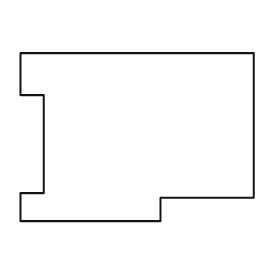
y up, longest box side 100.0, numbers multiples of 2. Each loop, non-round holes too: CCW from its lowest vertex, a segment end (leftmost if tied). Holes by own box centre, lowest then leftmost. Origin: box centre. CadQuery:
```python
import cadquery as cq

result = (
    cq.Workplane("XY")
    .moveTo(-50.0, -36.0)
    .lineTo(10.0, -36.0)
    .lineTo(10.0, -26.0)
    .lineTo(50.0, -26.0)
    .lineTo(50.0, 36.0)
    .lineTo(-50.0, 36.0)
    .lineTo(-50.0, 18.0)
    .lineTo(-40.0, 18.0)
    .lineTo(-40.0, -24.0)
    .lineTo(-50.0, -24.0)
    .close()
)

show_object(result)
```